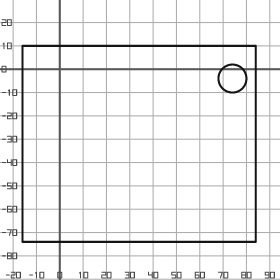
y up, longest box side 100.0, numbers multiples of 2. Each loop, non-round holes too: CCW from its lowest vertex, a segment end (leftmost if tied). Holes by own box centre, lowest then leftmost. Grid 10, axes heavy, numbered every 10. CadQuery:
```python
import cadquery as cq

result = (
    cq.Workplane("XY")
    .moveTo(-16.0, -74.0)
    .lineTo(84.0, -74.0)
    .lineTo(84.0, 10.0)
    .lineTo(-16.0, 10.0)
    .close()
    .moveTo(74.0, -4.0)
    .circle(6.0)
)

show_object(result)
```